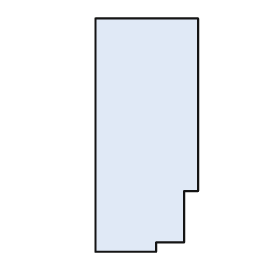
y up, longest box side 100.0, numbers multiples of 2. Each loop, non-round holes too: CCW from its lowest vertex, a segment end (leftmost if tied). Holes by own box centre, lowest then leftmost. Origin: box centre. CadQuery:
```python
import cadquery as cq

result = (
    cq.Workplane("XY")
    .moveTo(-22.0, -50.0)
    .lineTo(4.0, -50.0)
    .lineTo(4.0, -46.0)
    .lineTo(16.0, -46.0)
    .lineTo(16.0, -24.0)
    .lineTo(22.0, -24.0)
    .lineTo(22.0, 50.0)
    .lineTo(-22.0, 50.0)
    .close()
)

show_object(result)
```